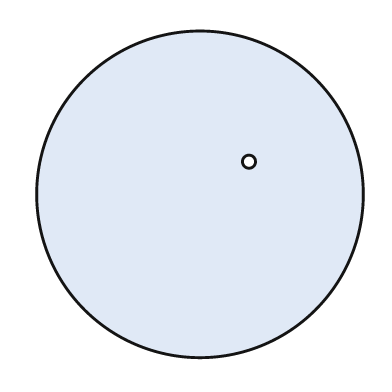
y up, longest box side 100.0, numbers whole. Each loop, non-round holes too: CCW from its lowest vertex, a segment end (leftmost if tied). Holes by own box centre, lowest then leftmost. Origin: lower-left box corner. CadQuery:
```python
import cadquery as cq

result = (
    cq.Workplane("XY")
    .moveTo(50.0, 50.0)
    .circle(50.0)
    .moveTo(65.0, 60.0)
    .circle(2.0)
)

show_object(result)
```